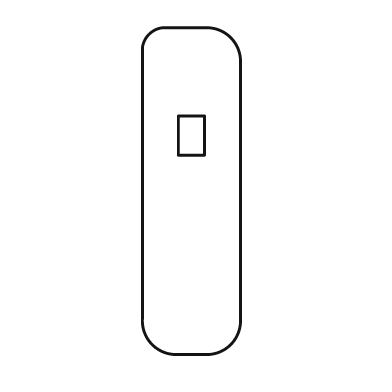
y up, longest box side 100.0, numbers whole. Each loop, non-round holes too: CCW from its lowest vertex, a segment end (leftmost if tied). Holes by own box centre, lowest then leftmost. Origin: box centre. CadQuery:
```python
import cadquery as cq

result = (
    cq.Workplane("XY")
    .moveTo(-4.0, -50.0)
    .lineTo(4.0, -50.0)
    .threePointArc((12.0, -47.0), (15.0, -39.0))
    .lineTo(15.0, 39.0)
    .threePointArc((12.0, 47.0), (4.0, 50.0))
    .lineTo(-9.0, 50.0)
    .threePointArc((-13.0, 48.0), (-15.0, 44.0))
    .lineTo(-15.0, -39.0)
    .threePointArc((-12.0, -47.0), (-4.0, -50.0))
    .close()
    .moveTo(-4.0, 11.0)
    .lineTo(4.0, 11.0)
    .lineTo(4.0, 23.0)
    .lineTo(-4.0, 23.0)
    .close()
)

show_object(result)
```